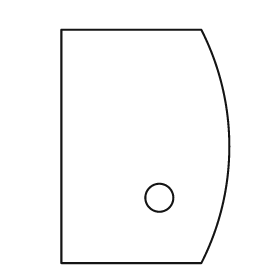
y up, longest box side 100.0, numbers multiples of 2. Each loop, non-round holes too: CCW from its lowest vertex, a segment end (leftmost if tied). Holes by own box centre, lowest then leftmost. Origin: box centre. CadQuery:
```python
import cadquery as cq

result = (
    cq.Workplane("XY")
    .moveTo(-36.0, -50.0)
    .lineTo(24.0, -50.0)
    .threePointArc((36.0, 0.0), (24.0, 50.0))
    .lineTo(-36.0, 50.0)
    .close()
    .moveTo(6.0, -22.0)
    .circle(6.0)
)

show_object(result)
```